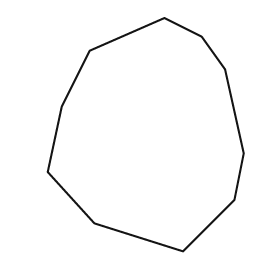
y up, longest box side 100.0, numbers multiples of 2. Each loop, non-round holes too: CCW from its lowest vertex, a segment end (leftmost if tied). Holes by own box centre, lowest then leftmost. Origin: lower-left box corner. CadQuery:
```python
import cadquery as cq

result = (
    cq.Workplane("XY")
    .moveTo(58.0, 0.0)
    .lineTo(80.0, 22.0)
    .lineTo(84.0, 42.0)
    .lineTo(76.0, 78.0)
    .lineTo(66.0, 92.0)
    .lineTo(50.0, 100.0)
    .lineTo(18.0, 86.0)
    .lineTo(6.0, 62.0)
    .lineTo(0.0, 34.0)
    .lineTo(20.0, 12.0)
    .close()
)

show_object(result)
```